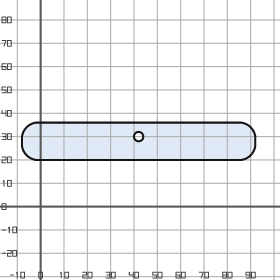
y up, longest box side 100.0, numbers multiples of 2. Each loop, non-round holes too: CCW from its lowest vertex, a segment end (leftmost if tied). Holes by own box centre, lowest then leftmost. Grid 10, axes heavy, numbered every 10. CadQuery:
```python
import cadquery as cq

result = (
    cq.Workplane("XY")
    .moveTo(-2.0, 20.0)
    .lineTo(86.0, 20.0)
    .threePointArc((90.0, 22.0), (92.0, 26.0))
    .lineTo(92.0, 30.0)
    .threePointArc((90.0, 34.0), (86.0, 36.0))
    .lineTo(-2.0, 36.0)
    .threePointArc((-6.0, 34.0), (-8.0, 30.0))
    .lineTo(-8.0, 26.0)
    .threePointArc((-6.0, 22.0), (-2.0, 20.0))
    .close()
    .moveTo(42.0, 30.0)
    .circle(2.0)
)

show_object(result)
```